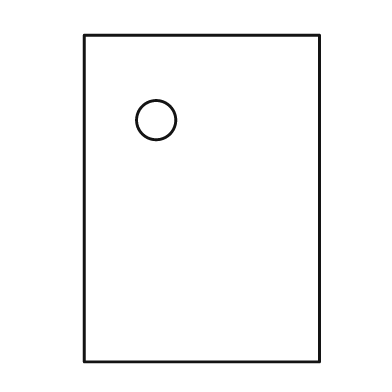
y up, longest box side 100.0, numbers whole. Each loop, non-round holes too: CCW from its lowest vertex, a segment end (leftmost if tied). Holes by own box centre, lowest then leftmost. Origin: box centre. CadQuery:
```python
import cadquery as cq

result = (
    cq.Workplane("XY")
    .moveTo(-36.0, -50.0)
    .lineTo(36.0, -50.0)
    .lineTo(36.0, 50.0)
    .lineTo(-36.0, 50.0)
    .close()
    .moveTo(-14.0, 24.0)
    .circle(6.0)
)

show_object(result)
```